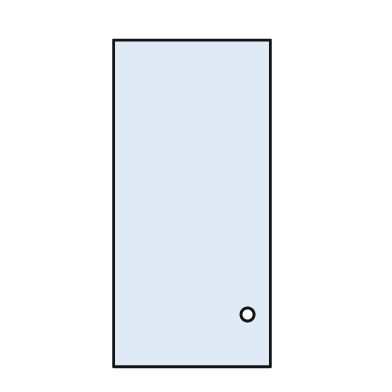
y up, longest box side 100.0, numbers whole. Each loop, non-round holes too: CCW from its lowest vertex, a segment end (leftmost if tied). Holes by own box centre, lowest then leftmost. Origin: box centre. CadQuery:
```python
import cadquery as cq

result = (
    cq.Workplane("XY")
    .moveTo(-24.0, -50.0)
    .lineTo(24.0, -50.0)
    .lineTo(24.0, 50.0)
    .lineTo(-24.0, 50.0)
    .close()
    .moveTo(17.0, -34.0)
    .circle(2.0)
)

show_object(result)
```